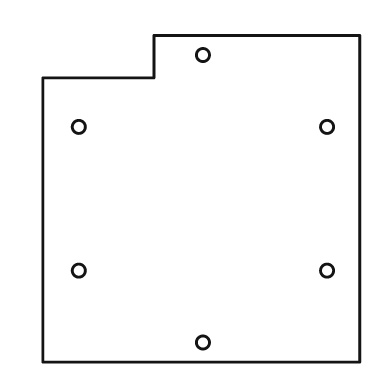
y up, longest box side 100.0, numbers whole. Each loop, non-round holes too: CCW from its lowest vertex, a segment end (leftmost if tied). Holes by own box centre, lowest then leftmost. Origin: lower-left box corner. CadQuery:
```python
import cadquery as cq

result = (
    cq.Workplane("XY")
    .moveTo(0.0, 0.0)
    .lineTo(97.0, 0.0)
    .lineTo(97.0, 100.0)
    .lineTo(34.0, 100.0)
    .lineTo(34.0, 87.0)
    .lineTo(0.0, 87.0)
    .close()
    .moveTo(49.0, 6.0)
    .circle(2.0)
    .moveTo(11.0, 28.0)
    .circle(2.0)
    .moveTo(87.0, 28.0)
    .circle(2.0)
    .moveTo(11.0, 72.0)
    .circle(2.0)
    .moveTo(87.0, 72.0)
    .circle(2.0)
    .moveTo(49.0, 94.0)
    .circle(2.0)
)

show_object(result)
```